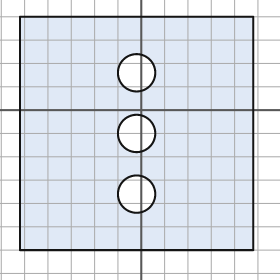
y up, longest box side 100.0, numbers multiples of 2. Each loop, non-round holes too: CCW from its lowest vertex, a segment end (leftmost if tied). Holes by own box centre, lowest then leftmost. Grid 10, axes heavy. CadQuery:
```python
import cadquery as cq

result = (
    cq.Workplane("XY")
    .moveTo(-52.0, -60.0)
    .lineTo(48.0, -60.0)
    .lineTo(48.0, 40.0)
    .lineTo(-52.0, 40.0)
    .close()
    .moveTo(-2.0, -36.0)
    .circle(8.0)
    .moveTo(-2.0, -10.0)
    .circle(8.0)
    .moveTo(-2.0, 16.0)
    .circle(8.0)
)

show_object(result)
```